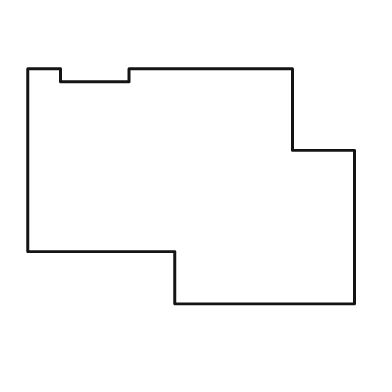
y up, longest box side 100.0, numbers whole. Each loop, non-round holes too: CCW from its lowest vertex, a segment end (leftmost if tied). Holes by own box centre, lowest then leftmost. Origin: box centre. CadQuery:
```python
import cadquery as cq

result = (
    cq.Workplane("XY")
    .moveTo(-5.0, -36.0)
    .lineTo(50.0, -36.0)
    .lineTo(50.0, 11.0)
    .lineTo(31.0, 11.0)
    .lineTo(31.0, 36.0)
    .lineTo(-19.0, 36.0)
    .lineTo(-19.0, 32.0)
    .lineTo(-40.0, 32.0)
    .lineTo(-40.0, 36.0)
    .lineTo(-50.0, 36.0)
    .lineTo(-50.0, -20.0)
    .lineTo(-5.0, -20.0)
    .close()
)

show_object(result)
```